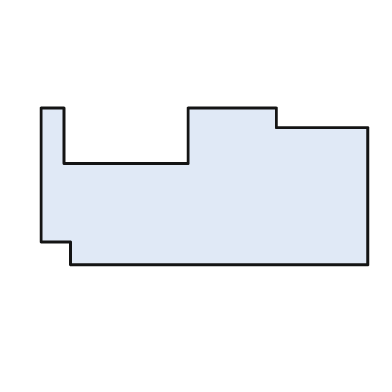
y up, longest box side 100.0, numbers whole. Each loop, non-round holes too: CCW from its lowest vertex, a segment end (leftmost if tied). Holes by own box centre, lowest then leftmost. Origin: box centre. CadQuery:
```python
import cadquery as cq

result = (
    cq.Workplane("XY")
    .moveTo(-41.0, -24.0)
    .lineTo(50.0, -24.0)
    .lineTo(50.0, 18.0)
    .lineTo(22.0, 18.0)
    .lineTo(22.0, 24.0)
    .lineTo(-5.0, 24.0)
    .lineTo(-5.0, 7.0)
    .lineTo(-43.0, 7.0)
    .lineTo(-43.0, 24.0)
    .lineTo(-50.0, 24.0)
    .lineTo(-50.0, -17.0)
    .lineTo(-41.0, -17.0)
    .close()
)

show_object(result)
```